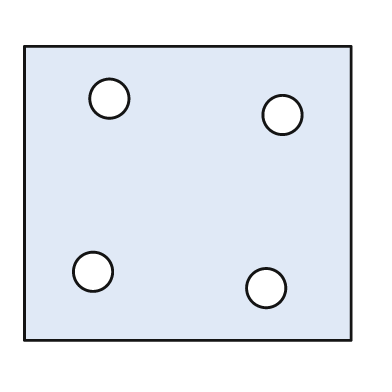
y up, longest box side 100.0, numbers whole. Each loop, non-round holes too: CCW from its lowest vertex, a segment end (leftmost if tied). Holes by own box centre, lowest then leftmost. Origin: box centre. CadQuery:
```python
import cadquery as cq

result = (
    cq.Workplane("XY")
    .moveTo(-50.0, -45.0)
    .lineTo(50.0, -45.0)
    .lineTo(50.0, 45.0)
    .lineTo(-50.0, 45.0)
    .close()
    .moveTo(24.0, -29.0)
    .circle(6.0)
    .moveTo(-29.0, -24.0)
    .circle(6.0)
    .moveTo(29.0, 24.0)
    .circle(6.0)
    .moveTo(-24.0, 29.0)
    .circle(6.0)
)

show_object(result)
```